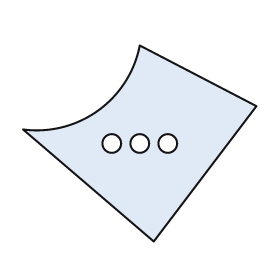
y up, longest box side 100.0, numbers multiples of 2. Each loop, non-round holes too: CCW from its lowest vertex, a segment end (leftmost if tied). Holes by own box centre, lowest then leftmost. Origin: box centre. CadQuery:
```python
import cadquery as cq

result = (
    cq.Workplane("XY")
    .moveTo(6.0, -42.0)
    .lineTo(50.0, 16.0)
    .lineTo(0.0, 42.0)
    .threePointArc((-18.0, 14.0), (-50.0, 6.0))
    .close()
    .moveTo(-12.0, 0.0)
    .circle(4.0)
    .moveTo(0.0, 0.0)
    .circle(4.0)
    .moveTo(12.0, 0.0)
    .circle(4.0)
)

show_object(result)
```